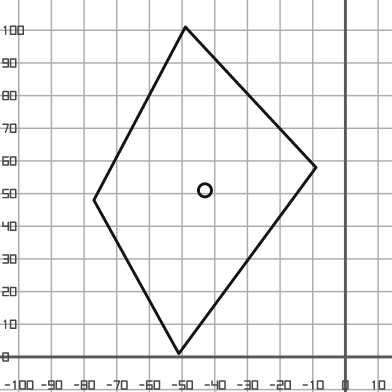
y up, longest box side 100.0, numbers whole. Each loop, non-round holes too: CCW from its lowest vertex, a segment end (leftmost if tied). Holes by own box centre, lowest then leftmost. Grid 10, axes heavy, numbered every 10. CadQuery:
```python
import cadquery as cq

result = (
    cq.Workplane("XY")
    .moveTo(-51.0, 1.0)
    .lineTo(-9.0, 58.0)
    .lineTo(-49.0, 101.0)
    .lineTo(-77.0, 48.0)
    .close()
    .moveTo(-43.0, 51.0)
    .circle(2.0)
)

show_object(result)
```